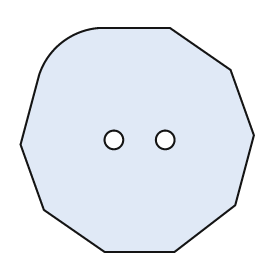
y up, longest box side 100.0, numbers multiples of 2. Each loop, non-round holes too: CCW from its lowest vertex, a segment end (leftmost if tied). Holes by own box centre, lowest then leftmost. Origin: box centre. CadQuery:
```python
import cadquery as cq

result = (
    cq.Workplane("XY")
    .moveTo(-14.0, -48.0)
    .lineTo(16.0, -48.0)
    .lineTo(42.0, -28.0)
    .lineTo(50.0, 2.0)
    .lineTo(40.0, 30.0)
    .lineTo(14.0, 48.0)
    .lineTo(-16.0, 48.0)
    .threePointArc((-32.0, 42.0), (-42.0, 28.0))
    .lineTo(-50.0, -2.0)
    .lineTo(-40.0, -30.0)
    .close()
    .moveTo(-10.0, 0.0)
    .circle(4.0)
    .moveTo(12.0, 0.0)
    .circle(4.0)
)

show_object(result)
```